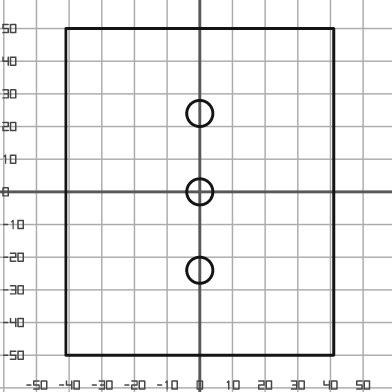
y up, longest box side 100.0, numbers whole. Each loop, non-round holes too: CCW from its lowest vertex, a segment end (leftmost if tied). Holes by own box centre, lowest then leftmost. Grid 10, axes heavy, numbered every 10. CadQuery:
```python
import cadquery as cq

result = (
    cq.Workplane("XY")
    .moveTo(-41.0, -50.0)
    .lineTo(41.0, -50.0)
    .lineTo(41.0, 50.0)
    .lineTo(-41.0, 50.0)
    .close()
    .moveTo(0.0, -24.0)
    .circle(4.0)
    .moveTo(0.0, 0.0)
    .circle(4.0)
    .moveTo(0.0, 24.0)
    .circle(4.0)
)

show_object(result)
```